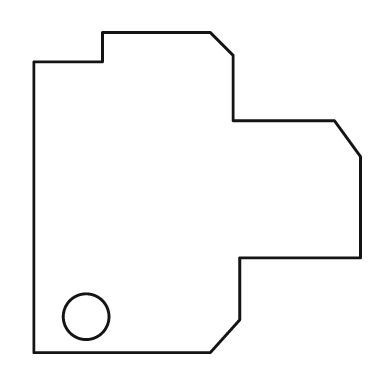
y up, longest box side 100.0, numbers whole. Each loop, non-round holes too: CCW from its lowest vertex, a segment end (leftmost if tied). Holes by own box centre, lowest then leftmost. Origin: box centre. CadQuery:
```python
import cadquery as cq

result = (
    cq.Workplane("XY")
    .moveTo(-50.0, -49.0)
    .lineTo(4.0, -49.0)
    .lineTo(13.0, -39.0)
    .lineTo(13.0, -20.0)
    .lineTo(50.0, -20.0)
    .lineTo(50.0, 11.0)
    .lineTo(42.0, 22.0)
    .lineTo(11.0, 22.0)
    .lineTo(11.0, 42.0)
    .lineTo(4.0, 49.0)
    .lineTo(-29.0, 49.0)
    .lineTo(-29.0, 40.0)
    .lineTo(-50.0, 40.0)
    .close()
    .moveTo(-34.0, -38.0)
    .circle(7.0)
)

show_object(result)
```